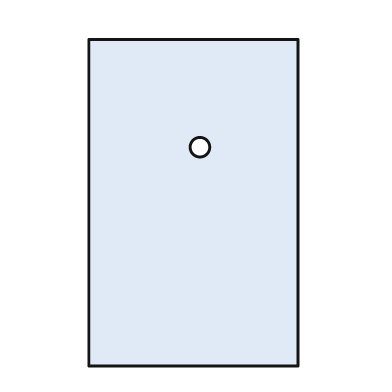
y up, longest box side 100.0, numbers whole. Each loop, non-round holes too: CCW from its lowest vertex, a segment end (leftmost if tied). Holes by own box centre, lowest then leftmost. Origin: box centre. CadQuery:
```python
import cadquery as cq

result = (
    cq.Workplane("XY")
    .moveTo(-32.0, -50.0)
    .lineTo(32.0, -50.0)
    .lineTo(32.0, 50.0)
    .lineTo(-32.0, 50.0)
    .close()
    .moveTo(2.0, 17.0)
    .circle(3.0)
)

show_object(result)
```